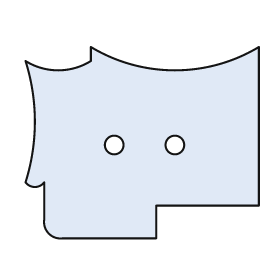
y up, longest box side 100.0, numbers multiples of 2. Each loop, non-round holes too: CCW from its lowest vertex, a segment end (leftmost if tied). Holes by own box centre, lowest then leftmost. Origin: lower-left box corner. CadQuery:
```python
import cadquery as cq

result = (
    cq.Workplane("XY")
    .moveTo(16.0, 0.0)
    .lineTo(56.0, 0.0)
    .lineTo(56.0, 14.0)
    .lineTo(100.0, 14.0)
    .lineTo(100.0, 82.0)
    .threePointArc((64.0, 72.0), (28.0, 82.0))
    .lineTo(28.0, 76.0)
    .threePointArc((14.0, 72.0), (0.0, 76.0))
    .threePointArc((4.0, 50.0), (0.0, 24.0))
    .threePointArc((4.0, 22.0), (8.0, 24.0))
    .lineTo(8.0, 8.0)
    .threePointArc((10.0, 2.0), (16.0, 0.0))
    .close()
    .moveTo(38.0, 40.0)
    .circle(4.0)
    .moveTo(64.0, 40.0)
    .circle(4.0)
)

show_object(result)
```